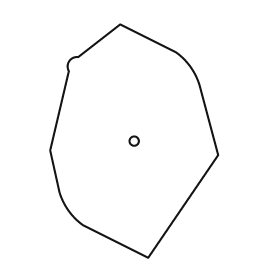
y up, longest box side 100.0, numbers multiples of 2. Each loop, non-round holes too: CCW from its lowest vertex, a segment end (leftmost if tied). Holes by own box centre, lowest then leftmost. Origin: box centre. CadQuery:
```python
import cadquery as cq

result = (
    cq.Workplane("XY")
    .moveTo(6.0, -50.0)
    .lineTo(36.0, -6.0)
    .lineTo(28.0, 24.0)
    .threePointArc((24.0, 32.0), (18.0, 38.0))
    .lineTo(-6.0, 50.0)
    .lineTo(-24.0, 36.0)
    .threePointArc((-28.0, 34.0), (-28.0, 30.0))
    .lineTo(-36.0, -4.0)
    .lineTo(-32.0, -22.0)
    .threePointArc((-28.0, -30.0), (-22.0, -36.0))
    .close()
    .moveTo(0.0, 0.0)
    .circle(2.0)
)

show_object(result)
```